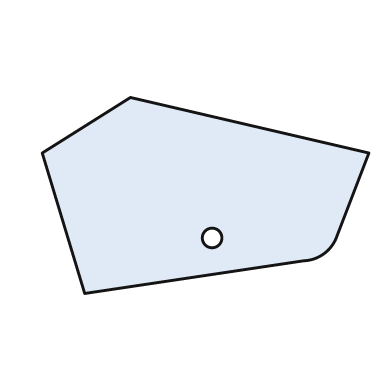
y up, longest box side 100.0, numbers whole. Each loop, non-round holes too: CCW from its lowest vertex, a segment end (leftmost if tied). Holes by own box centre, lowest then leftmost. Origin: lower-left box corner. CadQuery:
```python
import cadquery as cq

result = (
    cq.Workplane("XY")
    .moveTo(13.0, 0.0)
    .lineTo(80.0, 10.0)
    .threePointArc((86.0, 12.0), (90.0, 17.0))
    .lineTo(100.0, 43.0)
    .lineTo(27.0, 60.0)
    .lineTo(0.0, 43.0)
    .close()
    .moveTo(52.0, 17.0)
    .circle(3.0)
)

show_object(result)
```